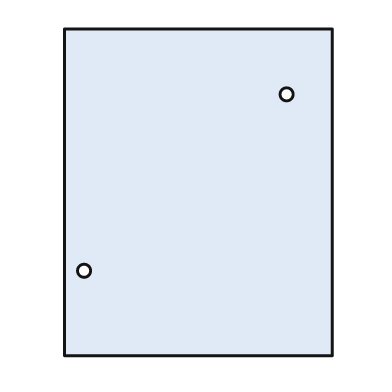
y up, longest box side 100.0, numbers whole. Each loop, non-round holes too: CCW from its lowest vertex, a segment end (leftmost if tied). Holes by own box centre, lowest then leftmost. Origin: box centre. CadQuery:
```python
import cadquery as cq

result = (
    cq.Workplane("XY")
    .moveTo(-41.0, -50.0)
    .lineTo(41.0, -50.0)
    .lineTo(41.0, 50.0)
    .lineTo(-41.0, 50.0)
    .close()
    .moveTo(-35.0, -24.0)
    .circle(2.0)
    .moveTo(27.0, 30.0)
    .circle(2.0)
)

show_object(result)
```